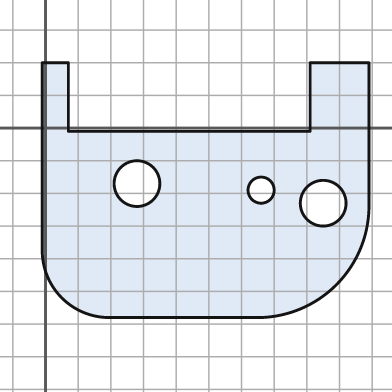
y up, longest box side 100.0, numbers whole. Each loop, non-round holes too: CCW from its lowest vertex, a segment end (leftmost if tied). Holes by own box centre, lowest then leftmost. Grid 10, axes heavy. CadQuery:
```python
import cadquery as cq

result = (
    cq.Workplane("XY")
    .moveTo(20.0, -58.0)
    .lineTo(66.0, -58.0)
    .threePointArc((89.0, -48.0), (99.0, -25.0))
    .lineTo(99.0, 20.0)
    .lineTo(81.0, 20.0)
    .lineTo(81.0, -1.0)
    .lineTo(7.0, -1.0)
    .lineTo(7.0, 20.0)
    .lineTo(-1.0, 20.0)
    .lineTo(-1.0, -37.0)
    .threePointArc((5.0, -52.0), (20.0, -58.0))
    .close()
    .moveTo(85.0, -23.0)
    .circle(7.0)
    .moveTo(66.0, -19.0)
    .circle(4.0)
    .moveTo(28.0, -17.0)
    .circle(7.0)
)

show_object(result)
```